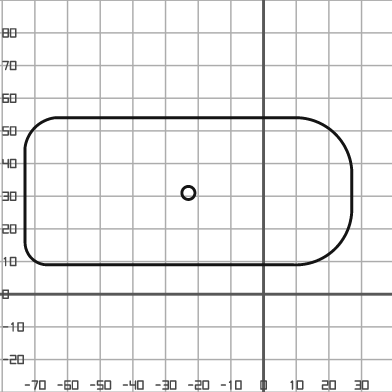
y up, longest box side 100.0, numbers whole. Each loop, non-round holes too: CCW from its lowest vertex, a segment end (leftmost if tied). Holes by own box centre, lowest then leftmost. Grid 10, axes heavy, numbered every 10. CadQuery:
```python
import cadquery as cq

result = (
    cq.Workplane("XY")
    .moveTo(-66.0, 9.0)
    .lineTo(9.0, 9.0)
    .threePointArc((22.0, 14.0), (27.0, 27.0))
    .lineTo(27.0, 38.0)
    .threePointArc((22.0, 49.0), (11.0, 54.0))
    .lineTo(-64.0, 54.0)
    .threePointArc((-70.0, 51.0), (-73.0, 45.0))
    .lineTo(-73.0, 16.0)
    .threePointArc((-71.0, 11.0), (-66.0, 9.0))
    .close()
    .moveTo(-23.0, 31.0)
    .circle(2.0)
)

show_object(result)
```